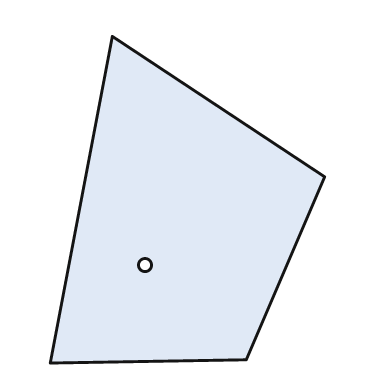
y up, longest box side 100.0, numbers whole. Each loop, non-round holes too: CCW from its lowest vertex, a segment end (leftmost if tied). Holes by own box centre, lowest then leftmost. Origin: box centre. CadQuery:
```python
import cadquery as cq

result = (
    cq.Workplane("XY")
    .moveTo(-42.0, -50.0)
    .lineTo(18.0, -49.0)
    .lineTo(42.0, 7.0)
    .lineTo(-23.0, 50.0)
    .close()
    .moveTo(-13.0, -20.0)
    .circle(2.0)
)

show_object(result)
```